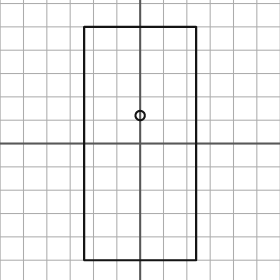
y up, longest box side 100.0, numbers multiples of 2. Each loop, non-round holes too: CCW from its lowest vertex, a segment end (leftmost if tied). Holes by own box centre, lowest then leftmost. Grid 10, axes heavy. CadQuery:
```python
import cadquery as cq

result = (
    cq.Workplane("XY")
    .moveTo(-24.0, -50.0)
    .lineTo(24.0, -50.0)
    .lineTo(24.0, 50.0)
    .lineTo(-24.0, 50.0)
    .close()
    .moveTo(0.0, 12.0)
    .circle(2.0)
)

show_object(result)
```